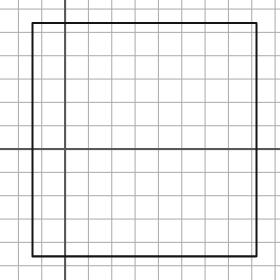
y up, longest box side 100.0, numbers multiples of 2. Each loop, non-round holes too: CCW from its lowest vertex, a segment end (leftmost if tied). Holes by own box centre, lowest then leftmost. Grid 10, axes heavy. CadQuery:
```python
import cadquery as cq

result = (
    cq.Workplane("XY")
    .moveTo(-14.0, -46.0)
    .lineTo(82.0, -46.0)
    .lineTo(82.0, 54.0)
    .lineTo(-14.0, 54.0)
    .close()
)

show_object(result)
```